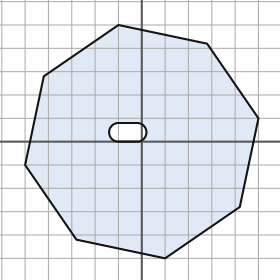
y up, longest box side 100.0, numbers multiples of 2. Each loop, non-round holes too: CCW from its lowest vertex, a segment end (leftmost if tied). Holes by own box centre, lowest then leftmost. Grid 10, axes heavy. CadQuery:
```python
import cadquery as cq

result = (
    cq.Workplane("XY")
    .moveTo(10.0, -50.0)
    .lineTo(42.0, -28.0)
    .lineTo(50.0, 10.0)
    .lineTo(28.0, 42.0)
    .lineTo(-10.0, 50.0)
    .lineTo(-42.0, 28.0)
    .lineTo(-50.0, -10.0)
    .lineTo(-28.0, -42.0)
    .close()
    .moveTo(-10.0, 0.0)
    .lineTo(-2.0, 0.0)
    .threePointArc((2.0, 4.0), (-2.0, 8.0))
    .lineTo(-10.0, 8.0)
    .threePointArc((-14.0, 4.0), (-10.0, 0.0))
    .close()
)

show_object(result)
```